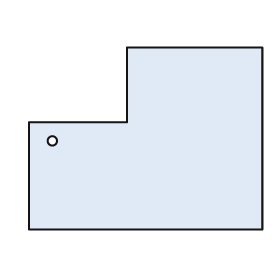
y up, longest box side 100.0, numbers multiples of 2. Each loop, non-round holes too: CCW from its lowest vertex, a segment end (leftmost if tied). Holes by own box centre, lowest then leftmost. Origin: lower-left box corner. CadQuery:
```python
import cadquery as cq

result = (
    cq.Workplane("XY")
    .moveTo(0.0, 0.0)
    .lineTo(100.0, 0.0)
    .lineTo(100.0, 78.0)
    .lineTo(42.0, 78.0)
    .lineTo(42.0, 46.0)
    .lineTo(0.0, 46.0)
    .close()
    .moveTo(10.0, 38.0)
    .circle(2.0)
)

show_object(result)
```